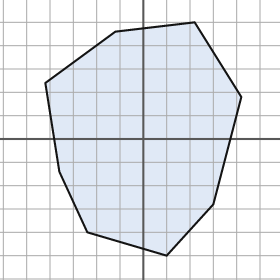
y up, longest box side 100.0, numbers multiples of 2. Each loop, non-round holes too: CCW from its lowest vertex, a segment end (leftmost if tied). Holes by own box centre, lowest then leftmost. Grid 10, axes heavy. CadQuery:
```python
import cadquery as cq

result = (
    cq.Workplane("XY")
    .moveTo(10.0, -50.0)
    .lineTo(30.0, -28.0)
    .lineTo(42.0, 18.0)
    .lineTo(22.0, 50.0)
    .lineTo(-12.0, 46.0)
    .lineTo(-42.0, 24.0)
    .lineTo(-36.0, -14.0)
    .lineTo(-24.0, -40.0)
    .close()
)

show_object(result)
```